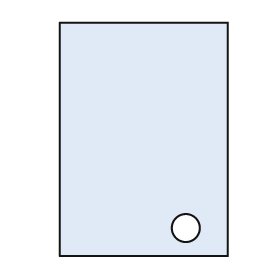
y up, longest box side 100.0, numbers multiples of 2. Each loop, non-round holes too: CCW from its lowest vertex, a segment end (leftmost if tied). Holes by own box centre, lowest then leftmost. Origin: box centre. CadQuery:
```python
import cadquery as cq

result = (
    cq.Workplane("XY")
    .moveTo(-36.0, -50.0)
    .lineTo(36.0, -50.0)
    .lineTo(36.0, 50.0)
    .lineTo(-36.0, 50.0)
    .close()
    .moveTo(18.0, -38.0)
    .circle(6.0)
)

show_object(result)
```